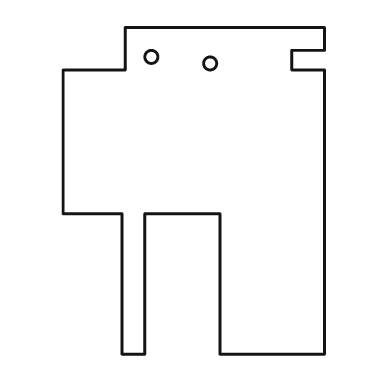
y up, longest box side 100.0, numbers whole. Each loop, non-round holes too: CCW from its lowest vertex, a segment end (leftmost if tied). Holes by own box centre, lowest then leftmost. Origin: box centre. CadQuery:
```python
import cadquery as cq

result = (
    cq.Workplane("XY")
    .moveTo(-22.0, -50.0)
    .lineTo(-15.0, -50.0)
    .lineTo(-15.0, -7.0)
    .lineTo(8.0, -7.0)
    .lineTo(8.0, -50.0)
    .lineTo(40.0, -50.0)
    .lineTo(40.0, 37.0)
    .lineTo(30.0, 37.0)
    .lineTo(30.0, 43.0)
    .lineTo(40.0, 43.0)
    .lineTo(40.0, 50.0)
    .lineTo(-21.0, 50.0)
    .lineTo(-21.0, 37.0)
    .lineTo(-40.0, 37.0)
    .lineTo(-40.0, -7.0)
    .lineTo(-22.0, -7.0)
    .close()
    .moveTo(5.0, 39.0)
    .circle(2.0)
    .moveTo(-13.0, 41.0)
    .circle(2.0)
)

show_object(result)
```